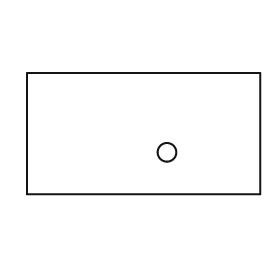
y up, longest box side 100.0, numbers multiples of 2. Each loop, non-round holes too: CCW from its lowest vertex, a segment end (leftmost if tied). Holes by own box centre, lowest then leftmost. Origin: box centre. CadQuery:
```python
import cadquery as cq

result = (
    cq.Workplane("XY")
    .moveTo(-50.0, -26.0)
    .lineTo(50.0, -26.0)
    .lineTo(50.0, 26.0)
    .lineTo(-50.0, 26.0)
    .close()
    .moveTo(10.0, -8.0)
    .circle(4.0)
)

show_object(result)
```